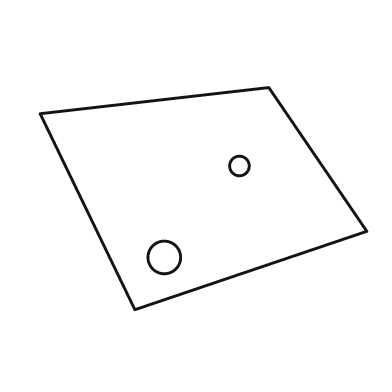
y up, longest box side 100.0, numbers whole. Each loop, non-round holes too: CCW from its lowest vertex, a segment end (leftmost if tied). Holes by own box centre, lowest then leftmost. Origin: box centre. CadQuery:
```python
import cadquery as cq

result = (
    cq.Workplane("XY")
    .moveTo(-21.0, -34.0)
    .lineTo(50.0, -10.0)
    .lineTo(20.0, 34.0)
    .lineTo(-50.0, 26.0)
    .close()
    .moveTo(-12.0, -18.0)
    .circle(5.0)
    .moveTo(11.0, 10.0)
    .circle(3.0)
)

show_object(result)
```